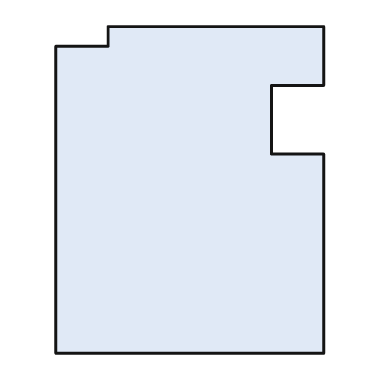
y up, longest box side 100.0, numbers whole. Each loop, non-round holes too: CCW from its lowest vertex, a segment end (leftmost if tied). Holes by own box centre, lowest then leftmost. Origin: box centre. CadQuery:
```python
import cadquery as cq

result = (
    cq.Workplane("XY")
    .moveTo(-41.0, -50.0)
    .lineTo(41.0, -50.0)
    .lineTo(41.0, 11.0)
    .lineTo(25.0, 11.0)
    .lineTo(25.0, 32.0)
    .lineTo(41.0, 32.0)
    .lineTo(41.0, 50.0)
    .lineTo(-25.0, 50.0)
    .lineTo(-25.0, 44.0)
    .lineTo(-41.0, 44.0)
    .close()
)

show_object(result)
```